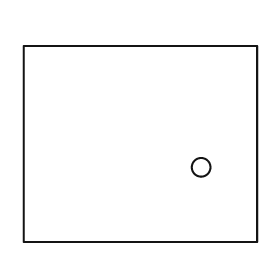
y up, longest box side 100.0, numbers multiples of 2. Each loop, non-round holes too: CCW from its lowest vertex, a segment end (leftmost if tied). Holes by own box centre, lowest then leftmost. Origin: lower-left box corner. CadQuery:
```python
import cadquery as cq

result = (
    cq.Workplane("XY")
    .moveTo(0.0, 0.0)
    .lineTo(100.0, 0.0)
    .lineTo(100.0, 84.0)
    .lineTo(0.0, 84.0)
    .close()
    .moveTo(76.0, 32.0)
    .circle(4.0)
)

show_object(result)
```